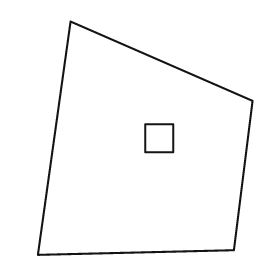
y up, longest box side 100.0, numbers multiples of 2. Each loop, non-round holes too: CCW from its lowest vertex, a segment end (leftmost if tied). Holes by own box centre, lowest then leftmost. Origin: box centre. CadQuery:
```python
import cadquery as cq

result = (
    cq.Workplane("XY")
    .moveTo(-46.0, -50.0)
    .lineTo(38.0, -48.0)
    .lineTo(46.0, 16.0)
    .lineTo(-32.0, 50.0)
    .close()
    .moveTo(0.0, -6.0)
    .lineTo(12.0, -6.0)
    .lineTo(12.0, 6.0)
    .lineTo(0.0, 6.0)
    .close()
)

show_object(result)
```